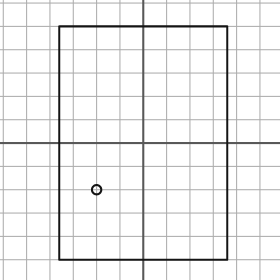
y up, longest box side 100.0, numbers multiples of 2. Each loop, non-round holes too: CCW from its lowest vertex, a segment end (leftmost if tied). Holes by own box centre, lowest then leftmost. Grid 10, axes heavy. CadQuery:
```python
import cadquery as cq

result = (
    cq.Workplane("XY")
    .moveTo(-36.0, -50.0)
    .lineTo(36.0, -50.0)
    .lineTo(36.0, 50.0)
    .lineTo(-36.0, 50.0)
    .close()
    .moveTo(-20.0, -20.0)
    .circle(2.0)
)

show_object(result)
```